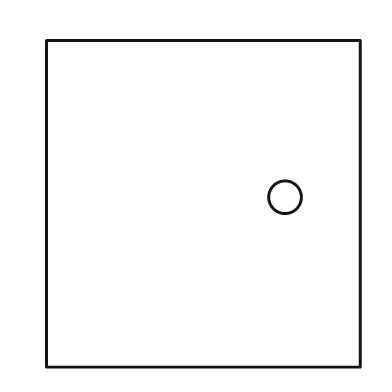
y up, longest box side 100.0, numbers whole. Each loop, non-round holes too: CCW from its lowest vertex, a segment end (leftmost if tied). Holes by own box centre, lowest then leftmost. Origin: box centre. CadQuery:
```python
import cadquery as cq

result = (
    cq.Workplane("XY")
    .moveTo(-48.0, -50.0)
    .lineTo(48.0, -50.0)
    .lineTo(48.0, 50.0)
    .lineTo(-48.0, 50.0)
    .close()
    .moveTo(25.0, 2.0)
    .circle(5.0)
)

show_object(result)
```